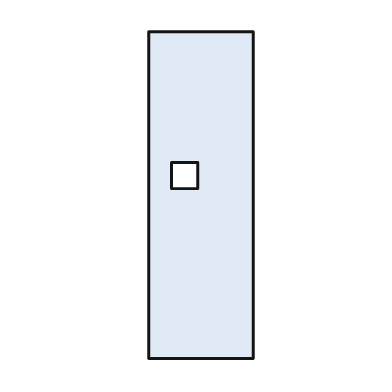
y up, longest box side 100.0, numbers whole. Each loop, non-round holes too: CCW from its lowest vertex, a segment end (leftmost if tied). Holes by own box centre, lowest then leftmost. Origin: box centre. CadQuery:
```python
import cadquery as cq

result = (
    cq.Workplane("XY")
    .moveTo(-16.0, -50.0)
    .lineTo(16.0, -50.0)
    .lineTo(16.0, 50.0)
    .lineTo(-16.0, 50.0)
    .close()
    .moveTo(-9.0, 2.0)
    .lineTo(-1.0, 2.0)
    .lineTo(-1.0, 10.0)
    .lineTo(-9.0, 10.0)
    .close()
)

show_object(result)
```